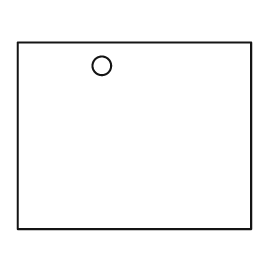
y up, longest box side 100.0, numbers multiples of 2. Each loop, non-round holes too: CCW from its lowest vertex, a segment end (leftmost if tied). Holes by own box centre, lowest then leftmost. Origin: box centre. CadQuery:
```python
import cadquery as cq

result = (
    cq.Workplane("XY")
    .moveTo(-50.0, -40.0)
    .lineTo(50.0, -40.0)
    .lineTo(50.0, 40.0)
    .lineTo(-50.0, 40.0)
    .close()
    .moveTo(-14.0, 30.0)
    .circle(4.0)
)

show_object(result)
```